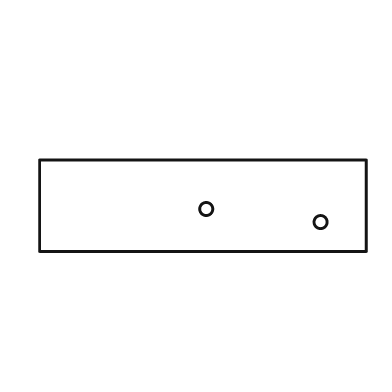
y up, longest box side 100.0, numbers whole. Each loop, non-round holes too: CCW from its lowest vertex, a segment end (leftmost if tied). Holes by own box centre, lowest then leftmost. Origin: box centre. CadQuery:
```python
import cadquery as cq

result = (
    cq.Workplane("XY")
    .moveTo(-50.0, -14.0)
    .lineTo(50.0, -14.0)
    .lineTo(50.0, 14.0)
    .lineTo(-50.0, 14.0)
    .close()
    .moveTo(36.0, -5.0)
    .circle(2.0)
    .moveTo(1.0, -1.0)
    .circle(2.0)
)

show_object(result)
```